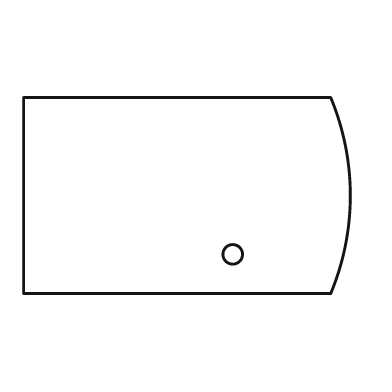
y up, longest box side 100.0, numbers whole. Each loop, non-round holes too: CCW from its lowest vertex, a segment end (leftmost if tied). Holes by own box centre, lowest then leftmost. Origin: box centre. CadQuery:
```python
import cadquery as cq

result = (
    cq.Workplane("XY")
    .moveTo(-50.0, -30.0)
    .lineTo(44.0, -30.0)
    .threePointArc((50.0, 0.0), (44.0, 30.0))
    .lineTo(-50.0, 30.0)
    .close()
    .moveTo(14.0, -18.0)
    .circle(3.0)
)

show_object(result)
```